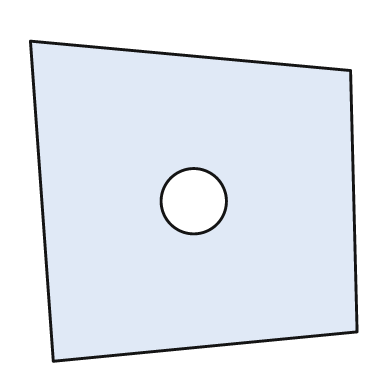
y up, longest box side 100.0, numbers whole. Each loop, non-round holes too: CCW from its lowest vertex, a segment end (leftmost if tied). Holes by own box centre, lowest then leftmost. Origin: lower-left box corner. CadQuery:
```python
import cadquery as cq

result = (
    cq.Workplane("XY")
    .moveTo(7.0, 0.0)
    .lineTo(100.0, 9.0)
    .lineTo(98.0, 89.0)
    .lineTo(0.0, 98.0)
    .close()
    .moveTo(50.0, 49.0)
    .circle(10.0)
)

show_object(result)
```